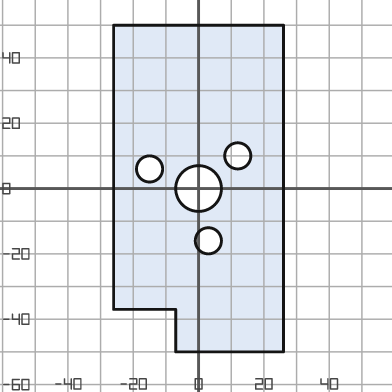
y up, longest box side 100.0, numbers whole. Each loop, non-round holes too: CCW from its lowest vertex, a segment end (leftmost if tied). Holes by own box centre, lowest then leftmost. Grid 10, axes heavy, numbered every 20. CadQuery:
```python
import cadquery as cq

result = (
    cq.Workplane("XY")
    .moveTo(-7.0, -50.0)
    .lineTo(26.0, -50.0)
    .lineTo(26.0, 50.0)
    .lineTo(-26.0, 50.0)
    .lineTo(-26.0, -37.0)
    .lineTo(-7.0, -37.0)
    .close()
    .moveTo(3.0, -16.0)
    .circle(4.0)
    .moveTo(0.0, 0.0)
    .circle(7.0)
    .moveTo(-15.0, 6.0)
    .circle(4.0)
    .moveTo(12.0, 10.0)
    .circle(4.0)
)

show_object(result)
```